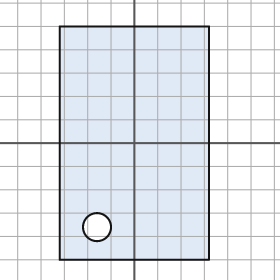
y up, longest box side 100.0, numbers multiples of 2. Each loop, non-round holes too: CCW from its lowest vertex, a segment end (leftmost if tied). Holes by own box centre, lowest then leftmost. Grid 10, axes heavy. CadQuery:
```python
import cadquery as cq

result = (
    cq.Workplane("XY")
    .moveTo(-32.0, -50.0)
    .lineTo(32.0, -50.0)
    .lineTo(32.0, 50.0)
    .lineTo(-32.0, 50.0)
    .close()
    .moveTo(-16.0, -36.0)
    .circle(6.0)
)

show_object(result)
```